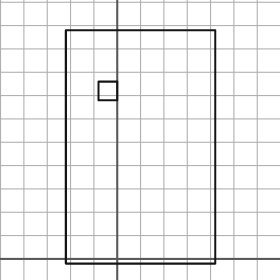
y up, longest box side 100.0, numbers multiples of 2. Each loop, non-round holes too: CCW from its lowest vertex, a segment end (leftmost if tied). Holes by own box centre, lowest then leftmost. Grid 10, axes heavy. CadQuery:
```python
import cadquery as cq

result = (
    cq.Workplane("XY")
    .moveTo(-22.0, -2.0)
    .lineTo(42.0, -2.0)
    .lineTo(42.0, 98.0)
    .lineTo(-22.0, 98.0)
    .close()
    .moveTo(-8.0, 68.0)
    .lineTo(0.0, 68.0)
    .lineTo(0.0, 76.0)
    .lineTo(-8.0, 76.0)
    .close()
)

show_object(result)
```